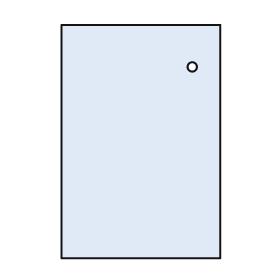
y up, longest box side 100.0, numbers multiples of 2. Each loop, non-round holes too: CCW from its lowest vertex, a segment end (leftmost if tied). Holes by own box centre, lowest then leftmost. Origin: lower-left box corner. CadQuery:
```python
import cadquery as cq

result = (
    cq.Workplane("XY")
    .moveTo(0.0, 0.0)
    .lineTo(68.0, 0.0)
    .lineTo(68.0, 100.0)
    .lineTo(0.0, 100.0)
    .close()
    .moveTo(56.0, 82.0)
    .circle(2.0)
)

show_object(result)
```